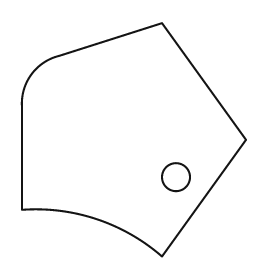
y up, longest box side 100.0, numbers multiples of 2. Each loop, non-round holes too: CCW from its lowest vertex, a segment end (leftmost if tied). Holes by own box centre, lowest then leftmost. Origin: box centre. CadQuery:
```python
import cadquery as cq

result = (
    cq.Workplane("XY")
    .moveTo(12.0, -50.0)
    .lineTo(48.0, 0.0)
    .lineTo(12.0, 50.0)
    .lineTo(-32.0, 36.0)
    .threePointArc((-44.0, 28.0), (-48.0, 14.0))
    .lineTo(-48.0, -30.0)
    .threePointArc((-16.0, -34.0), (12.0, -50.0))
    .close()
    .moveTo(18.0, -16.0)
    .circle(6.0)
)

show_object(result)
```